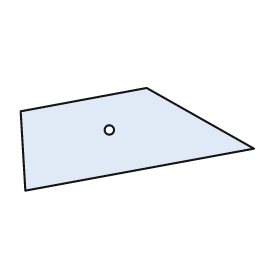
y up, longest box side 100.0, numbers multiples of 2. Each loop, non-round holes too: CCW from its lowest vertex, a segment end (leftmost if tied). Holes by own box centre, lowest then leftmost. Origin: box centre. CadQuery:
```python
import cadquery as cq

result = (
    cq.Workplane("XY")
    .moveTo(-48.0, -22.0)
    .lineTo(50.0, -4.0)
    .lineTo(4.0, 22.0)
    .lineTo(-50.0, 12.0)
    .close()
    .moveTo(-12.0, 4.0)
    .circle(2.0)
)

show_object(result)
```